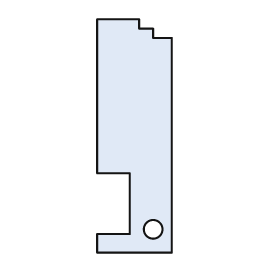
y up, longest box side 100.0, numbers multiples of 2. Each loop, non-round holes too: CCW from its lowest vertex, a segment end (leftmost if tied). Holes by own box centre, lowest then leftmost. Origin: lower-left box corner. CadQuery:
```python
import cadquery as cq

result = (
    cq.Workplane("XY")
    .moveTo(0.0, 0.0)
    .lineTo(32.0, 0.0)
    .lineTo(32.0, 92.0)
    .lineTo(24.0, 92.0)
    .lineTo(24.0, 96.0)
    .lineTo(18.0, 96.0)
    .lineTo(18.0, 100.0)
    .lineTo(0.0, 100.0)
    .lineTo(0.0, 34.0)
    .lineTo(14.0, 34.0)
    .lineTo(14.0, 8.0)
    .lineTo(0.0, 8.0)
    .close()
    .moveTo(24.0, 10.0)
    .circle(4.0)
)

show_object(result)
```